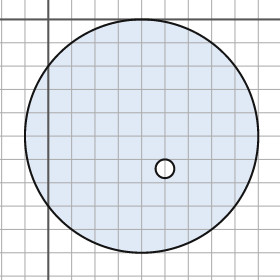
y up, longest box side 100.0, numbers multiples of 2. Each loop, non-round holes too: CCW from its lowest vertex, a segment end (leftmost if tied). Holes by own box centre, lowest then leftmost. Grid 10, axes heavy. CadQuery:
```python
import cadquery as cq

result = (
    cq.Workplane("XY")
    .moveTo(40.0, -50.0)
    .circle(50.0)
    .moveTo(50.0, -64.0)
    .circle(4.0)
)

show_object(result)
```